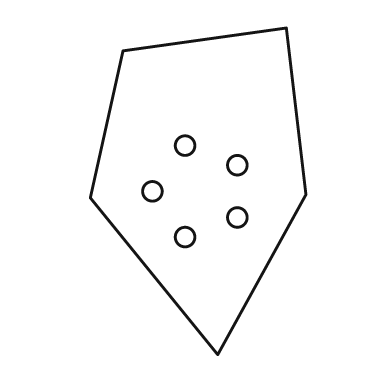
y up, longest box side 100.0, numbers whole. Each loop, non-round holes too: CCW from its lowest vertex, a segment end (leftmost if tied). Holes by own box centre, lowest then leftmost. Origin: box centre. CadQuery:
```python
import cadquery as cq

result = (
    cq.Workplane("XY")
    .moveTo(6.0, -50.0)
    .lineTo(33.0, -1.0)
    .lineTo(27.0, 50.0)
    .lineTo(-23.0, 43.0)
    .lineTo(-33.0, -2.0)
    .close()
    .moveTo(-4.0, -14.0)
    .circle(3.0)
    .moveTo(12.0, -8.0)
    .circle(3.0)
    .moveTo(-14.0, 0.0)
    .circle(3.0)
    .moveTo(12.0, 8.0)
    .circle(3.0)
    .moveTo(-4.0, 14.0)
    .circle(3.0)
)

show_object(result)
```